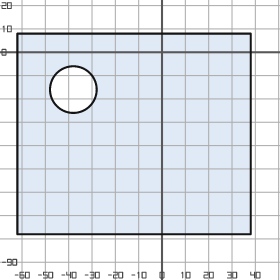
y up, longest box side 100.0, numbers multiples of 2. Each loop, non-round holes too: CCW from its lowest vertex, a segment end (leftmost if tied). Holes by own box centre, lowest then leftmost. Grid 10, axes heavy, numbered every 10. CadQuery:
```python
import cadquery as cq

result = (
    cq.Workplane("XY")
    .moveTo(-62.0, -78.0)
    .lineTo(38.0, -78.0)
    .lineTo(38.0, 8.0)
    .lineTo(-62.0, 8.0)
    .close()
    .moveTo(-38.0, -16.0)
    .circle(10.0)
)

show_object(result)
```